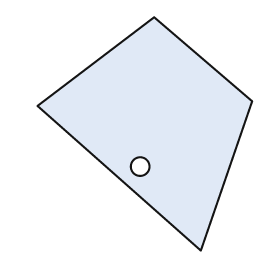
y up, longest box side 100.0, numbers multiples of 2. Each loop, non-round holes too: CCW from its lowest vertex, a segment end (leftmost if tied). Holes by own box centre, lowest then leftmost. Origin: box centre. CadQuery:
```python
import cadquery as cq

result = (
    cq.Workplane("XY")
    .moveTo(24.0, -50.0)
    .lineTo(46.0, 14.0)
    .lineTo(4.0, 50.0)
    .lineTo(-46.0, 12.0)
    .close()
    .moveTo(-2.0, -14.0)
    .circle(4.0)
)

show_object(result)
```